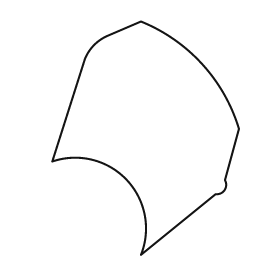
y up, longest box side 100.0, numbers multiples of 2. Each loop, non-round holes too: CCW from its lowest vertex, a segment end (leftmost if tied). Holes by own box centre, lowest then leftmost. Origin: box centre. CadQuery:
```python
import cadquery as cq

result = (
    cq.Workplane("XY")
    .moveTo(-2.0, -50.0)
    .lineTo(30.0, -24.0)
    .threePointArc((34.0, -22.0), (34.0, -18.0))
    .lineTo(40.0, 4.0)
    .threePointArc((24.0, 32.0), (-2.0, 50.0))
    .lineTo(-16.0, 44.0)
    .threePointArc((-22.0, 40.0), (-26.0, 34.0))
    .lineTo(-40.0, -10.0)
    .threePointArc((-8.0, -18.0), (-2.0, -50.0))
    .close()
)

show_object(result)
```